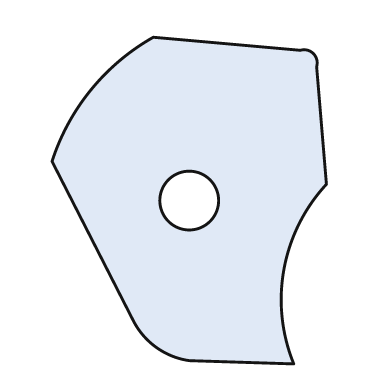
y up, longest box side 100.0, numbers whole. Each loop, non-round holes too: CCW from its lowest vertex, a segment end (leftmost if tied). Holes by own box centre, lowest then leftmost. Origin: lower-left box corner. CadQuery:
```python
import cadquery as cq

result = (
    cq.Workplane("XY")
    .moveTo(74.0, 0.0)
    .threePointArc((71.0, 29.0), (84.0, 55.0))
    .lineTo(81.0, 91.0)
    .threePointArc((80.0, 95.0), (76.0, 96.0))
    .lineTo(31.0, 100.0)
    .threePointArc((12.0, 84.0), (0.0, 62.0))
    .lineTo(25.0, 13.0)
    .threePointArc((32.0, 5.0), (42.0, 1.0))
    .close()
    .moveTo(42.0, 50.0)
    .circle(9.0)
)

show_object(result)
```